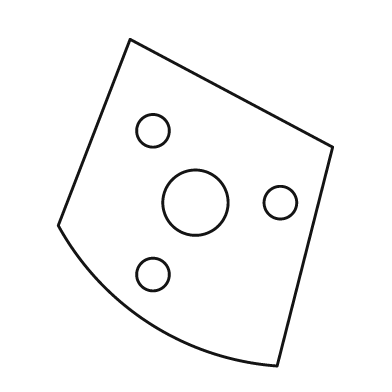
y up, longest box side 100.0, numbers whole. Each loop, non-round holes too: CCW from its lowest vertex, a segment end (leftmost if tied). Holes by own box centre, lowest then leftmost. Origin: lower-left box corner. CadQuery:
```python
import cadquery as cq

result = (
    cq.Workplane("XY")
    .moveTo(67.0, 0.0)
    .lineTo(84.0, 67.0)
    .lineTo(22.0, 100.0)
    .lineTo(0.0, 43.0)
    .threePointArc((28.0, 13.0), (67.0, 0.0))
    .close()
    .moveTo(29.0, 28.0)
    .circle(5.0)
    .moveTo(42.0, 50.0)
    .circle(10.0)
    .moveTo(68.0, 50.0)
    .circle(5.0)
    .moveTo(29.0, 72.0)
    .circle(5.0)
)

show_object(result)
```